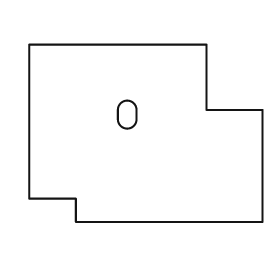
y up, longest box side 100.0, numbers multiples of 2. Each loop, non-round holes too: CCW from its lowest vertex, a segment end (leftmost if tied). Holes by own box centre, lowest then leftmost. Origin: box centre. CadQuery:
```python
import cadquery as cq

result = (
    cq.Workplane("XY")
    .moveTo(-30.0, -38.0)
    .lineTo(50.0, -38.0)
    .lineTo(50.0, 10.0)
    .lineTo(26.0, 10.0)
    .lineTo(26.0, 38.0)
    .lineTo(-50.0, 38.0)
    .lineTo(-50.0, -28.0)
    .lineTo(-30.0, -28.0)
    .close()
    .moveTo(-12.0, 6.0)
    .threePointArc((-8.0, 2.0), (-4.0, 6.0))
    .lineTo(-4.0, 10.0)
    .threePointArc((-8.0, 14.0), (-12.0, 10.0))
    .close()
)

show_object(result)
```